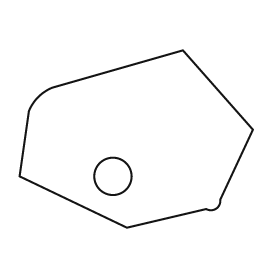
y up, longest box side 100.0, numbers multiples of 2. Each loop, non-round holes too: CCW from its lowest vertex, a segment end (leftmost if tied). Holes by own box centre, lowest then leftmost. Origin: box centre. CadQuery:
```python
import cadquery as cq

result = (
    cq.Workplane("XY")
    .moveTo(-4.0, -38.0)
    .lineTo(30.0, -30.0)
    .threePointArc((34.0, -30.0), (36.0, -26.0))
    .lineTo(50.0, 4.0)
    .lineTo(20.0, 38.0)
    .lineTo(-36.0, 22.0)
    .threePointArc((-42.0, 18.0), (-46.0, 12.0))
    .lineTo(-50.0, -16.0)
    .close()
    .moveTo(-10.0, -16.0)
    .circle(8.0)
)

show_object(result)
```